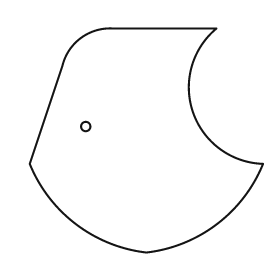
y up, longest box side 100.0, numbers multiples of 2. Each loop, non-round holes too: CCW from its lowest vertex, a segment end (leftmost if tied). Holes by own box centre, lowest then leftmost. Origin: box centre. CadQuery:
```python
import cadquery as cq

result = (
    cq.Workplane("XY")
    .moveTo(0.0, -48.0)
    .threePointArc((30.0, -36.0), (50.0, -10.0))
    .threePointArc((20.0, 12.0), (30.0, 48.0))
    .lineTo(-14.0, 48.0)
    .threePointArc((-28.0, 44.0), (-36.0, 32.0))
    .lineTo(-50.0, -10.0)
    .threePointArc((-30.0, -36.0), (0.0, -48.0))
    .close()
    .moveTo(-26.0, 6.0)
    .circle(2.0)
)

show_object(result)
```